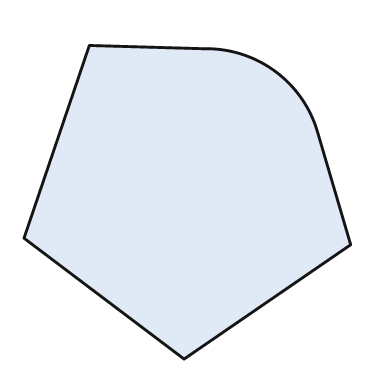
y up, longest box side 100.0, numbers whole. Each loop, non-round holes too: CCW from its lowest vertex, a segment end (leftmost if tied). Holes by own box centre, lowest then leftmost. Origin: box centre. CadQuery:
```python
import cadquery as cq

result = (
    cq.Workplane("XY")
    .moveTo(-1.0, -48.0)
    .lineTo(50.0, -13.0)
    .lineTo(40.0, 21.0)
    .threePointArc((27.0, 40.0), (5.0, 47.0))
    .lineTo(-30.0, 48.0)
    .lineTo(-50.0, -11.0)
    .close()
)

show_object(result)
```